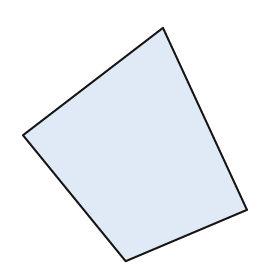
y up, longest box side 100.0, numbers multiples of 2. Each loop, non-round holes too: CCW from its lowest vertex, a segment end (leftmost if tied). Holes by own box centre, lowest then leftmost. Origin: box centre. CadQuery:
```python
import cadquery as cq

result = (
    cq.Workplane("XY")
    .moveTo(-4.0, -50.0)
    .lineTo(48.0, -28.0)
    .lineTo(12.0, 50.0)
    .lineTo(-48.0, 4.0)
    .close()
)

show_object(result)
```